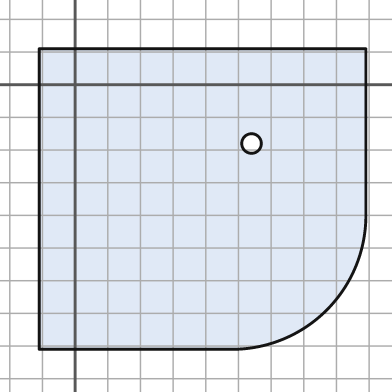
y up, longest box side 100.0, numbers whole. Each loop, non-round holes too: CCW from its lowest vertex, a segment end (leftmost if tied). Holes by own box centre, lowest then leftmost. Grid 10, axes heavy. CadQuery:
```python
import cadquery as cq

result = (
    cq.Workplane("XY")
    .moveTo(-11.0, -81.0)
    .lineTo(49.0, -81.0)
    .threePointArc((77.0, -69.0), (89.0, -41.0))
    .lineTo(89.0, 11.0)
    .lineTo(-11.0, 11.0)
    .close()
    .moveTo(54.0, -18.0)
    .circle(3.0)
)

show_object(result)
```